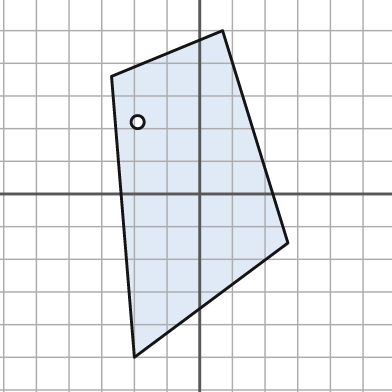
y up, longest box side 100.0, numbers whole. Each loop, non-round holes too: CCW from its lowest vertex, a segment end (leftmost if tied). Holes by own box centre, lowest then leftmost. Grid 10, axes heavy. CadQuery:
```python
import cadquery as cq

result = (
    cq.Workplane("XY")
    .moveTo(-20.0, -50.0)
    .lineTo(27.0, -15.0)
    .lineTo(7.0, 50.0)
    .lineTo(-27.0, 36.0)
    .close()
    .moveTo(-19.0, 22.0)
    .circle(2.0)
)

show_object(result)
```